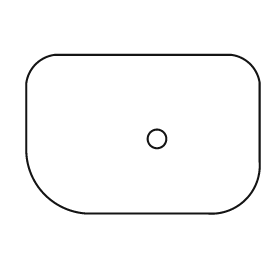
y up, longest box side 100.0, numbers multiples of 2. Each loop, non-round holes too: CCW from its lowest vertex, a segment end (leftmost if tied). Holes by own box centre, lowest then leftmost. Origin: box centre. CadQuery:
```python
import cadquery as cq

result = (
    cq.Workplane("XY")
    .moveTo(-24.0, -34.0)
    .lineTo(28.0, -34.0)
    .threePointArc((44.0, -28.0), (50.0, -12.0))
    .lineTo(50.0, 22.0)
    .threePointArc((46.0, 30.0), (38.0, 34.0))
    .lineTo(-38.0, 34.0)
    .threePointArc((-46.0, 30.0), (-50.0, 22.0))
    .lineTo(-50.0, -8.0)
    .threePointArc((-42.0, -26.0), (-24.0, -34.0))
    .close()
    .moveTo(6.0, -2.0)
    .circle(4.0)
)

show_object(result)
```